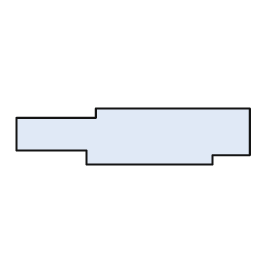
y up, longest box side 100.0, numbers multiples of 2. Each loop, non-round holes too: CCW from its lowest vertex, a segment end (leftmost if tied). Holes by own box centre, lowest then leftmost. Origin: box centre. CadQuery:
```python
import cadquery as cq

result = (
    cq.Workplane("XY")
    .moveTo(-20.0, -12.0)
    .lineTo(34.0, -12.0)
    .lineTo(34.0, -8.0)
    .lineTo(50.0, -8.0)
    .lineTo(50.0, 12.0)
    .lineTo(-16.0, 12.0)
    .lineTo(-16.0, 8.0)
    .lineTo(-50.0, 8.0)
    .lineTo(-50.0, -6.0)
    .lineTo(-20.0, -6.0)
    .close()
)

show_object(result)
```